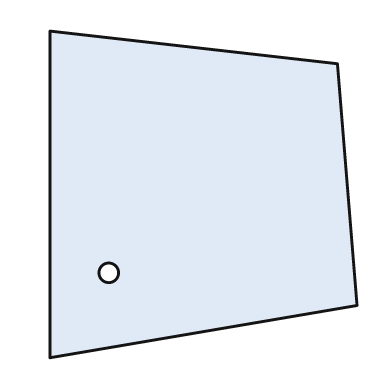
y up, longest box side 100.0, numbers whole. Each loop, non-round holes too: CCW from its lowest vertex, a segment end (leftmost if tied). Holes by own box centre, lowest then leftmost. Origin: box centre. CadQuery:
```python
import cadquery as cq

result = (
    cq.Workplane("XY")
    .moveTo(-47.0, -50.0)
    .lineTo(47.0, -34.0)
    .lineTo(41.0, 40.0)
    .lineTo(-47.0, 50.0)
    .close()
    .moveTo(-29.0, -24.0)
    .circle(3.0)
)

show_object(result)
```